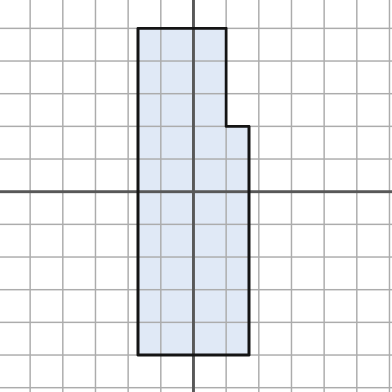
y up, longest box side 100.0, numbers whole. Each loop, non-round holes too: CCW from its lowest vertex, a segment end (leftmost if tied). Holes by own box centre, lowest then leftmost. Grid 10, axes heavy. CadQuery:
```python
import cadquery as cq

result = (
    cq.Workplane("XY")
    .moveTo(-17.0, -50.0)
    .lineTo(17.0, -50.0)
    .lineTo(17.0, 20.0)
    .lineTo(10.0, 20.0)
    .lineTo(10.0, 50.0)
    .lineTo(-17.0, 50.0)
    .close()
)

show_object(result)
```